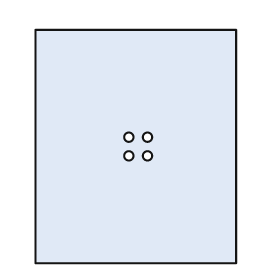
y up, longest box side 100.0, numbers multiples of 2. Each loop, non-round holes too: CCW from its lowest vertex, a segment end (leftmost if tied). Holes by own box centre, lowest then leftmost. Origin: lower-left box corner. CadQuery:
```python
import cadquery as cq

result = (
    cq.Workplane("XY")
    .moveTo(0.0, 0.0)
    .lineTo(86.0, 0.0)
    .lineTo(86.0, 100.0)
    .lineTo(0.0, 100.0)
    .close()
    .moveTo(40.0, 46.0)
    .circle(2.0)
    .moveTo(48.0, 46.0)
    .circle(2.0)
    .moveTo(40.0, 54.0)
    .circle(2.0)
    .moveTo(48.0, 54.0)
    .circle(2.0)
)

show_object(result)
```